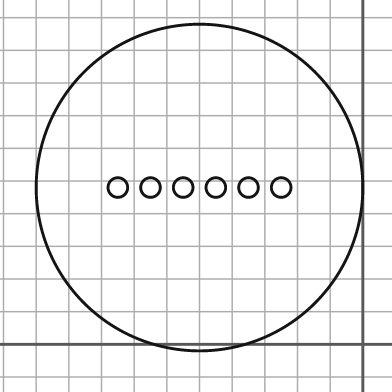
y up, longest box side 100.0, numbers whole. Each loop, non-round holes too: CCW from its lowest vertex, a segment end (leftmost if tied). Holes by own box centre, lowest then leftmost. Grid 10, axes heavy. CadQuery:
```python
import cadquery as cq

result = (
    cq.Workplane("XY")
    .moveTo(-50.0, 48.0)
    .circle(50.0)
    .moveTo(-75.0, 48.0)
    .circle(3.0)
    .moveTo(-65.0, 48.0)
    .circle(3.0)
    .moveTo(-55.0, 48.0)
    .circle(3.0)
    .moveTo(-45.0, 48.0)
    .circle(3.0)
    .moveTo(-35.0, 48.0)
    .circle(3.0)
    .moveTo(-25.0, 48.0)
    .circle(3.0)
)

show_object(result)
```